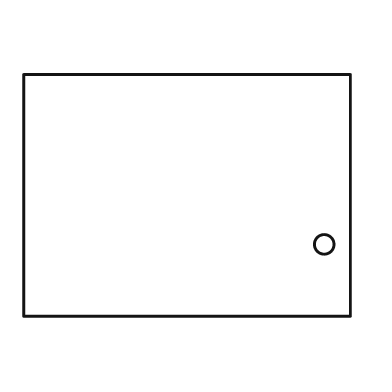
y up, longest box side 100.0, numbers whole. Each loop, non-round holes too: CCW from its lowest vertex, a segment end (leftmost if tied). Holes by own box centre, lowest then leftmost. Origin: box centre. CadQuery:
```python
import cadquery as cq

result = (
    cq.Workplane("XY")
    .moveTo(-50.0, -37.0)
    .lineTo(50.0, -37.0)
    .lineTo(50.0, 37.0)
    .lineTo(-50.0, 37.0)
    .close()
    .moveTo(42.0, -15.0)
    .circle(3.0)
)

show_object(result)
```